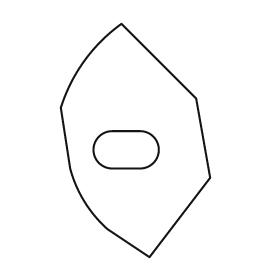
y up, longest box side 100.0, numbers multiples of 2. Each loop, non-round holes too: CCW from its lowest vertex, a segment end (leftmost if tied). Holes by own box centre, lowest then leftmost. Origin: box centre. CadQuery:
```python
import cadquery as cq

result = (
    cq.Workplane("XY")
    .moveTo(6.0, -50.0)
    .lineTo(32.0, -16.0)
    .lineTo(26.0, 18.0)
    .lineTo(-6.0, 50.0)
    .threePointArc((-22.0, 34.0), (-32.0, 14.0))
    .lineTo(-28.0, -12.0)
    .threePointArc((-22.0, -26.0), (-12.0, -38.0))
    .close()
    .moveTo(-10.0, -12.0)
    .lineTo(2.0, -12.0)
    .threePointArc((10.0, -4.0), (2.0, 4.0))
    .lineTo(-10.0, 4.0)
    .threePointArc((-18.0, -4.0), (-10.0, -12.0))
    .close()
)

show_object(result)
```